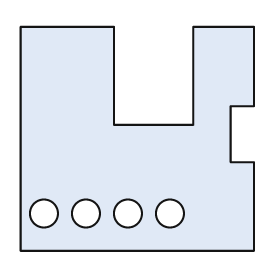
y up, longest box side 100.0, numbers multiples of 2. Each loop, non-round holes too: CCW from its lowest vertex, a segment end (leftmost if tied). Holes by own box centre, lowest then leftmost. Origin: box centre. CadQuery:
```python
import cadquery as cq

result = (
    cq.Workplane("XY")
    .moveTo(-50.0, -48.0)
    .lineTo(50.0, -48.0)
    .lineTo(50.0, -10.0)
    .lineTo(40.0, -10.0)
    .lineTo(40.0, 14.0)
    .lineTo(50.0, 14.0)
    .lineTo(50.0, 48.0)
    .lineTo(24.0, 48.0)
    .lineTo(24.0, 6.0)
    .lineTo(-10.0, 6.0)
    .lineTo(-10.0, 48.0)
    .lineTo(-50.0, 48.0)
    .close()
    .moveTo(-40.0, -32.0)
    .circle(6.0)
    .moveTo(-22.0, -32.0)
    .circle(6.0)
    .moveTo(-4.0, -32.0)
    .circle(6.0)
    .moveTo(14.0, -32.0)
    .circle(6.0)
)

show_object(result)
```